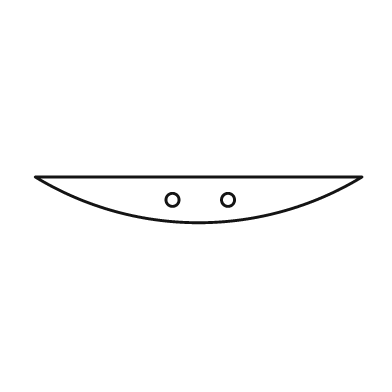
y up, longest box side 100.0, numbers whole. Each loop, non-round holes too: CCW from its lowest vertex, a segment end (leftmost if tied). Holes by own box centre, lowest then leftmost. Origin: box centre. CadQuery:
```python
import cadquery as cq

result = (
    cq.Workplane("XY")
    .moveTo(-50.0, 7.0)
    .threePointArc((0.0, -7.0), (50.0, 7.0))
    .close()
    .moveTo(-8.0, 0.0)
    .circle(2.0)
    .moveTo(9.0, 0.0)
    .circle(2.0)
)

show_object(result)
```